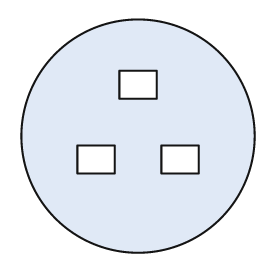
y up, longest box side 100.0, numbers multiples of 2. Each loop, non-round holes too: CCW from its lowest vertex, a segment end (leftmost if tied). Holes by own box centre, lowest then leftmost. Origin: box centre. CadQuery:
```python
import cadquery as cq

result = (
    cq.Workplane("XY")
    .moveTo(0.0, 0.0)
    .circle(50.0)
    .moveTo(-26.0, -16.0)
    .lineTo(-10.0, -16.0)
    .lineTo(-10.0, -4.0)
    .lineTo(-26.0, -4.0)
    .close()
    .moveTo(10.0, -16.0)
    .lineTo(26.0, -16.0)
    .lineTo(26.0, -4.0)
    .lineTo(10.0, -4.0)
    .close()
    .moveTo(-8.0, 16.0)
    .lineTo(8.0, 16.0)
    .lineTo(8.0, 28.0)
    .lineTo(-8.0, 28.0)
    .close()
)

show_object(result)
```